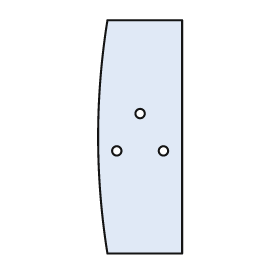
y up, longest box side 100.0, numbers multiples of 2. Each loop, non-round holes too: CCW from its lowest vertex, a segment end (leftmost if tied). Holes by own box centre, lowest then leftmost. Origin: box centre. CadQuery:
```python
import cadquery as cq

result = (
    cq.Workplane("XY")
    .moveTo(-14.0, -50.0)
    .lineTo(18.0, -50.0)
    .lineTo(18.0, 50.0)
    .lineTo(-14.0, 50.0)
    .threePointArc((-18.0, 0.0), (-14.0, -50.0))
    .close()
    .moveTo(-10.0, -6.0)
    .circle(2.0)
    .moveTo(10.0, -6.0)
    .circle(2.0)
    .moveTo(0.0, 10.0)
    .circle(2.0)
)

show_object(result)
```